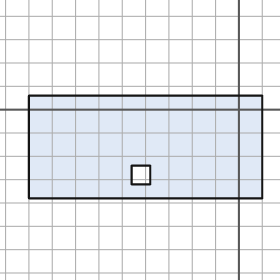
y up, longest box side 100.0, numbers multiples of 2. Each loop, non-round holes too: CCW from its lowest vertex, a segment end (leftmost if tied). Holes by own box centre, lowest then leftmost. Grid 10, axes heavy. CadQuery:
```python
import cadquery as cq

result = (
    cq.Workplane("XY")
    .moveTo(-90.0, -38.0)
    .lineTo(10.0, -38.0)
    .lineTo(10.0, 6.0)
    .lineTo(-90.0, 6.0)
    .close()
    .moveTo(-46.0, -32.0)
    .lineTo(-38.0, -32.0)
    .lineTo(-38.0, -24.0)
    .lineTo(-46.0, -24.0)
    .close()
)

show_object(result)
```